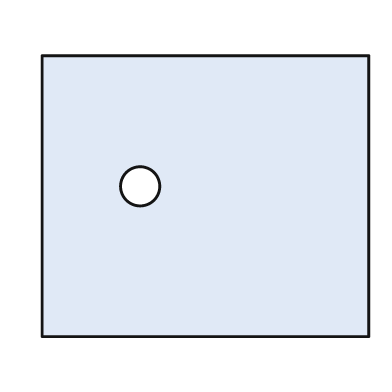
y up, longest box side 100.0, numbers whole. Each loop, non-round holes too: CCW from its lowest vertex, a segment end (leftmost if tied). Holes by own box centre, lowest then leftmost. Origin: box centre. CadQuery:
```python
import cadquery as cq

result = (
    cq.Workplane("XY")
    .moveTo(-50.0, -43.0)
    .lineTo(50.0, -43.0)
    .lineTo(50.0, 43.0)
    .lineTo(-50.0, 43.0)
    .close()
    .moveTo(-20.0, 3.0)
    .circle(6.0)
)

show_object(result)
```